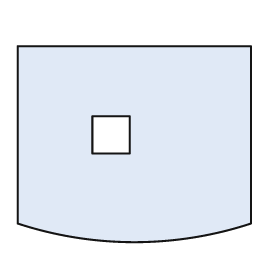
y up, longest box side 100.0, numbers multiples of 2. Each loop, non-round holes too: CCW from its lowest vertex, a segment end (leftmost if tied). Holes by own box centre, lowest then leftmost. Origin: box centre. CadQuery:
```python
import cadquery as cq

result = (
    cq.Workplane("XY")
    .moveTo(-50.0, -34.0)
    .threePointArc((0.0, -42.0), (50.0, -34.0))
    .lineTo(50.0, 42.0)
    .lineTo(-50.0, 42.0)
    .close()
    .moveTo(-18.0, -4.0)
    .lineTo(-2.0, -4.0)
    .lineTo(-2.0, 12.0)
    .lineTo(-18.0, 12.0)
    .close()
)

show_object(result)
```